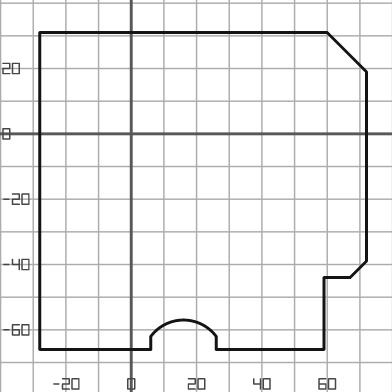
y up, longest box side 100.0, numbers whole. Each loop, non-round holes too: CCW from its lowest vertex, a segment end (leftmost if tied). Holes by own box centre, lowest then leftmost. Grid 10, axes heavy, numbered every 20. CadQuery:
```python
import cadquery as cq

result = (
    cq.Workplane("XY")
    .moveTo(-28.0, -66.0)
    .lineTo(6.0, -66.0)
    .lineTo(6.0, -62.0)
    .threePointArc((16.0, -57.0), (26.0, -62.0))
    .lineTo(26.0, -66.0)
    .lineTo(59.0, -66.0)
    .lineTo(59.0, -44.0)
    .lineTo(67.0, -44.0)
    .lineTo(72.0, -39.0)
    .lineTo(72.0, 19.0)
    .lineTo(60.0, 31.0)
    .lineTo(-28.0, 31.0)
    .close()
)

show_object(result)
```